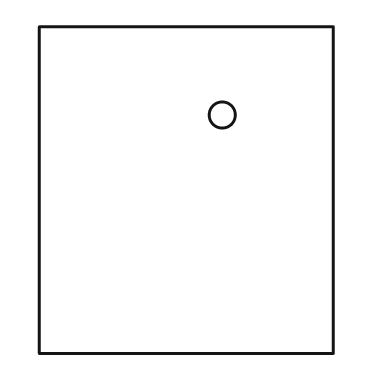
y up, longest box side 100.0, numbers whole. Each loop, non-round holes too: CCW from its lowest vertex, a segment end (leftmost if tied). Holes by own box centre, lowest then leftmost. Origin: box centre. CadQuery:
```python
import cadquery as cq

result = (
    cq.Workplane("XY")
    .moveTo(-45.0, -50.0)
    .lineTo(45.0, -50.0)
    .lineTo(45.0, 50.0)
    .lineTo(-45.0, 50.0)
    .close()
    .moveTo(11.0, 23.0)
    .circle(4.0)
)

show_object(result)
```